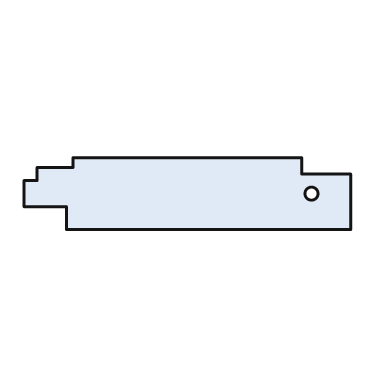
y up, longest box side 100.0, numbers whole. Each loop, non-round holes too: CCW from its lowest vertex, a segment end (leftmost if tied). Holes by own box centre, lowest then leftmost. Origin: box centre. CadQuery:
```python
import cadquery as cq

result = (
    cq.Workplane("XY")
    .moveTo(-37.0, -11.0)
    .lineTo(50.0, -11.0)
    .lineTo(50.0, 6.0)
    .lineTo(35.0, 6.0)
    .lineTo(35.0, 11.0)
    .lineTo(-35.0, 11.0)
    .lineTo(-35.0, 8.0)
    .lineTo(-46.0, 8.0)
    .lineTo(-46.0, 4.0)
    .lineTo(-50.0, 4.0)
    .lineTo(-50.0, -4.0)
    .lineTo(-37.0, -4.0)
    .close()
    .moveTo(38.0, 0.0)
    .circle(2.0)
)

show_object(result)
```